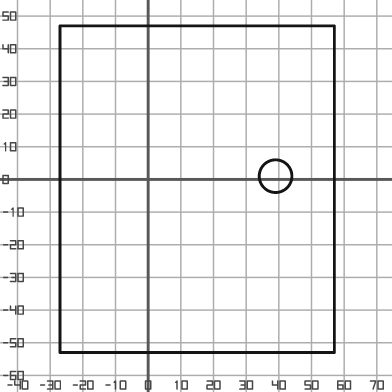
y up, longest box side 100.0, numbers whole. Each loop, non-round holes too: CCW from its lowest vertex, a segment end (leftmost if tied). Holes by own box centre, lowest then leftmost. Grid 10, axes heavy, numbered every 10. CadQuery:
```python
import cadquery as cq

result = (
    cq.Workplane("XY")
    .moveTo(-27.0, -53.0)
    .lineTo(57.0, -53.0)
    .lineTo(57.0, 47.0)
    .lineTo(-27.0, 47.0)
    .close()
    .moveTo(39.0, 1.0)
    .circle(5.0)
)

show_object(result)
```